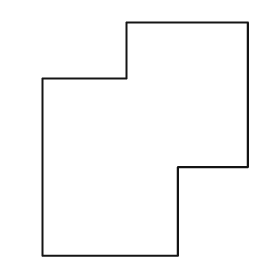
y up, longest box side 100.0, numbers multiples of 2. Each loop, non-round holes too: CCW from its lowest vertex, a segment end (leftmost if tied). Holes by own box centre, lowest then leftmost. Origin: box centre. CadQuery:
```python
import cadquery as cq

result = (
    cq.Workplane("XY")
    .moveTo(-44.0, -50.0)
    .lineTo(14.0, -50.0)
    .lineTo(14.0, -12.0)
    .lineTo(44.0, -12.0)
    .lineTo(44.0, 50.0)
    .lineTo(-8.0, 50.0)
    .lineTo(-8.0, 26.0)
    .lineTo(-44.0, 26.0)
    .close()
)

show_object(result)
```